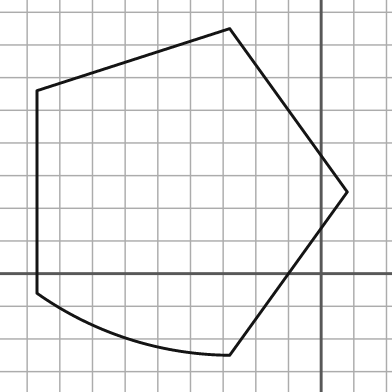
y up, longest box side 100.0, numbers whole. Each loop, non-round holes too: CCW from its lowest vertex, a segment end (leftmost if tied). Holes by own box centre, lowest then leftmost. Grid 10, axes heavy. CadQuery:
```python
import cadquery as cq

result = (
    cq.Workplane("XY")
    .moveTo(-28.0, -25.0)
    .lineTo(8.0, 25.0)
    .lineTo(-28.0, 75.0)
    .lineTo(-87.0, 56.0)
    .lineTo(-87.0, -6.0)
    .threePointArc((-59.0, -20.0), (-28.0, -25.0))
    .close()
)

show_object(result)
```